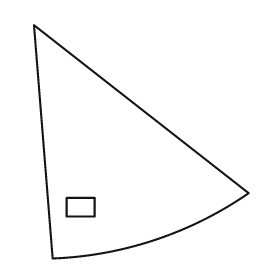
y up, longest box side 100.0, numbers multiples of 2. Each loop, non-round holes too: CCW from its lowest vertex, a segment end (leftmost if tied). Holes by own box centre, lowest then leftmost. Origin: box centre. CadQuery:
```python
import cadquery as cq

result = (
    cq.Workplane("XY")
    .moveTo(-38.0, -50.0)
    .threePointArc((6.0, -42.0), (46.0, -22.0))
    .lineTo(-46.0, 50.0)
    .close()
    .moveTo(-32.0, -32.0)
    .lineTo(-20.0, -32.0)
    .lineTo(-20.0, -24.0)
    .lineTo(-32.0, -24.0)
    .close()
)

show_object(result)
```